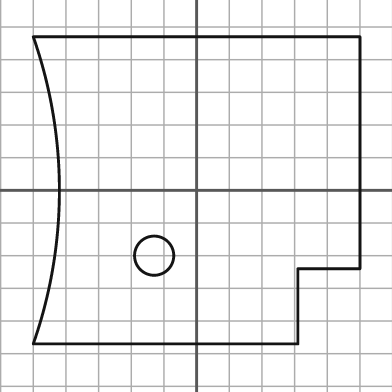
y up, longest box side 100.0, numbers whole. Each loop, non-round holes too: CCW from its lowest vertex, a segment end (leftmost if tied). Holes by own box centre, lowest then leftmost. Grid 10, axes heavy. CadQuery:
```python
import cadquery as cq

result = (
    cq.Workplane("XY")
    .moveTo(-50.0, -47.0)
    .lineTo(31.0, -47.0)
    .lineTo(31.0, -24.0)
    .lineTo(50.0, -24.0)
    .lineTo(50.0, 47.0)
    .lineTo(-50.0, 47.0)
    .threePointArc((-42.0, 0.0), (-50.0, -47.0))
    .close()
    .moveTo(-13.0, -20.0)
    .circle(6.0)
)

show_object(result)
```